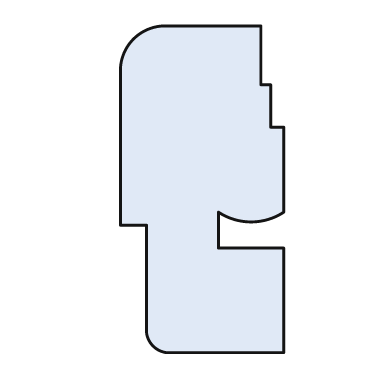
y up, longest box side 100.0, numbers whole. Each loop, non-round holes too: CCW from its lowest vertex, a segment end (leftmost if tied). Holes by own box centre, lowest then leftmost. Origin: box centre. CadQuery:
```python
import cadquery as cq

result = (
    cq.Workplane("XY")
    .moveTo(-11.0, -50.0)
    .lineTo(25.0, -50.0)
    .lineTo(25.0, -18.0)
    .lineTo(5.0, -18.0)
    .lineTo(5.0, -7.0)
    .threePointArc((15.0, -10.0), (25.0, -7.0))
    .lineTo(25.0, 19.0)
    .lineTo(21.0, 19.0)
    .lineTo(21.0, 32.0)
    .lineTo(18.0, 32.0)
    .lineTo(18.0, 50.0)
    .lineTo(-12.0, 50.0)
    .threePointArc((-21.0, 46.0), (-25.0, 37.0))
    .lineTo(-25.0, -11.0)
    .lineTo(-17.0, -11.0)
    .lineTo(-17.0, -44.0)
    .threePointArc((-15.0, -48.0), (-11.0, -50.0))
    .close()
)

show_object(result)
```